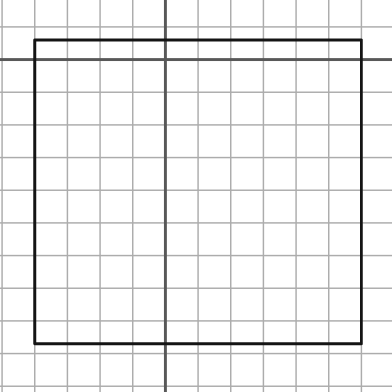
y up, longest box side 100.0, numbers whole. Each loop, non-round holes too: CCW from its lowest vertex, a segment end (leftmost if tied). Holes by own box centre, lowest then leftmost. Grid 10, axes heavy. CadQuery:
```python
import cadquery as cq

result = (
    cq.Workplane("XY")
    .moveTo(-40.0, -87.0)
    .lineTo(60.0, -87.0)
    .lineTo(60.0, 6.0)
    .lineTo(-40.0, 6.0)
    .close()
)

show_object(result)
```